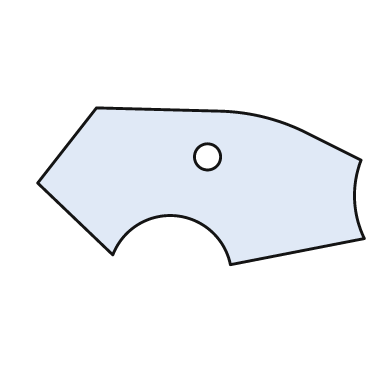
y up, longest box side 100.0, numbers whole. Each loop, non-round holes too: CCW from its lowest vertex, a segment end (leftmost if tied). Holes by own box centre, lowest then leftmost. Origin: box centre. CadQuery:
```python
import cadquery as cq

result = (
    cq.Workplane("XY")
    .moveTo(9.0, -24.0)
    .lineTo(50.0, -16.0)
    .threePointArc((47.0, -4.0), (49.0, 8.0))
    .lineTo(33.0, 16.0)
    .threePointArc((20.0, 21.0), (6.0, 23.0))
    .lineTo(-32.0, 24.0)
    .lineTo(-50.0, 1.0)
    .lineTo(-27.0, -21.0)
    .threePointArc((-8.0, -9.0), (9.0, -24.0))
    .close()
    .moveTo(2.0, 9.0)
    .circle(4.0)
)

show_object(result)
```